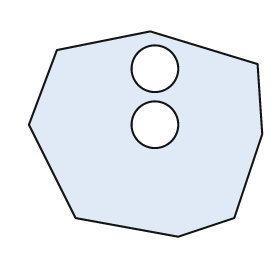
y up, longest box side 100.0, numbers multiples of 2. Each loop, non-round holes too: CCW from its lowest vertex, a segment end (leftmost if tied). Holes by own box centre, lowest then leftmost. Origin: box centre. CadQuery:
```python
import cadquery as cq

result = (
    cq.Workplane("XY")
    .moveTo(14.0, -44.0)
    .lineTo(38.0, -36.0)
    .lineTo(50.0, 0.0)
    .lineTo(48.0, 30.0)
    .lineTo(2.0, 44.0)
    .lineTo(-38.0, 36.0)
    .lineTo(-50.0, 4.0)
    .lineTo(-30.0, -36.0)
    .close()
    .moveTo(4.0, 4.0)
    .circle(10.0)
    .moveTo(4.0, 28.0)
    .circle(10.0)
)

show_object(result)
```